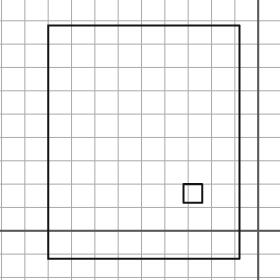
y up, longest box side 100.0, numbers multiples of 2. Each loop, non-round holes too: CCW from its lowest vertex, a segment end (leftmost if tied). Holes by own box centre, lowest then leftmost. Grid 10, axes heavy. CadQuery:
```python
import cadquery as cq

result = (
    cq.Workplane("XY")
    .moveTo(-90.0, -12.0)
    .lineTo(-8.0, -12.0)
    .lineTo(-8.0, 88.0)
    .lineTo(-90.0, 88.0)
    .close()
    .moveTo(-32.0, 12.0)
    .lineTo(-24.0, 12.0)
    .lineTo(-24.0, 20.0)
    .lineTo(-32.0, 20.0)
    .close()
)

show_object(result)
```